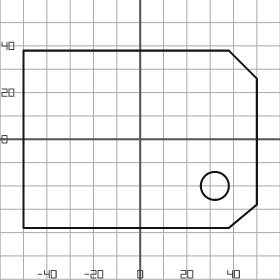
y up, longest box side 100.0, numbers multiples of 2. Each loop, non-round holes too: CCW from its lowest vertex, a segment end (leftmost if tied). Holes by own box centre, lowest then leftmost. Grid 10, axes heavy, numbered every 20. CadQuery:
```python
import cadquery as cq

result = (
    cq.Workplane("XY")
    .moveTo(-50.0, -38.0)
    .lineTo(38.0, -38.0)
    .lineTo(50.0, -28.0)
    .lineTo(50.0, 26.0)
    .lineTo(38.0, 38.0)
    .lineTo(-50.0, 38.0)
    .close()
    .moveTo(32.0, -20.0)
    .circle(6.0)
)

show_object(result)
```